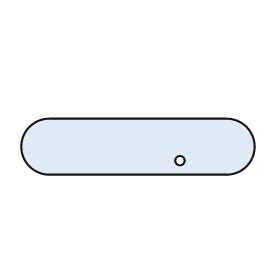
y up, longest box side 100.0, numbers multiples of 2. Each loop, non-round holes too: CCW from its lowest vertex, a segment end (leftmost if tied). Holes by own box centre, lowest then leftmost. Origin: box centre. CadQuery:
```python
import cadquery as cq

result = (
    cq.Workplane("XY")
    .moveTo(-38.0, -12.0)
    .lineTo(38.0, -12.0)
    .threePointArc((50.0, 0.0), (38.0, 12.0))
    .lineTo(-38.0, 12.0)
    .threePointArc((-50.0, 0.0), (-38.0, -12.0))
    .close()
    .moveTo(18.0, -6.0)
    .circle(2.0)
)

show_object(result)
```